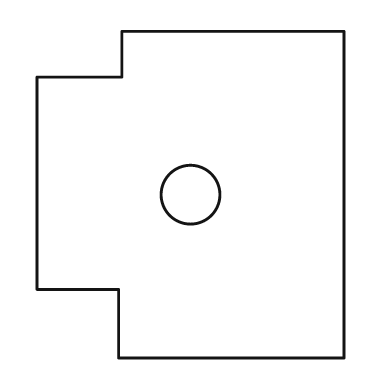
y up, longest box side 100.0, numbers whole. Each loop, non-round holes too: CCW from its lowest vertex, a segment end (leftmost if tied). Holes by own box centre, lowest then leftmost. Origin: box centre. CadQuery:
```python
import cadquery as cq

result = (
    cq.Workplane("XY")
    .moveTo(-22.0, -50.0)
    .lineTo(47.0, -50.0)
    .lineTo(47.0, 50.0)
    .lineTo(-21.0, 50.0)
    .lineTo(-21.0, 36.0)
    .lineTo(-47.0, 36.0)
    .lineTo(-47.0, -29.0)
    .lineTo(-22.0, -29.0)
    .close()
    .moveTo(0.0, 0.0)
    .circle(9.0)
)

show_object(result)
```